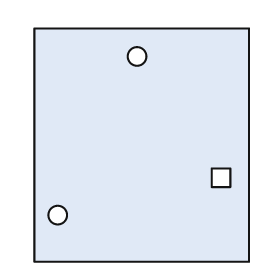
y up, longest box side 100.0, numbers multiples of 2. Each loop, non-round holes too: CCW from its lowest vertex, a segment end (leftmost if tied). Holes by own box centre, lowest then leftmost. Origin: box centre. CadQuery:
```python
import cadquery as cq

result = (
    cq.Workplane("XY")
    .moveTo(-46.0, -50.0)
    .lineTo(46.0, -50.0)
    .lineTo(46.0, 50.0)
    .lineTo(-46.0, 50.0)
    .close()
    .moveTo(-36.0, -30.0)
    .circle(4.0)
    .moveTo(30.0, -18.0)
    .lineTo(38.0, -18.0)
    .lineTo(38.0, -10.0)
    .lineTo(30.0, -10.0)
    .close()
    .moveTo(-2.0, 38.0)
    .circle(4.0)
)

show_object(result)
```